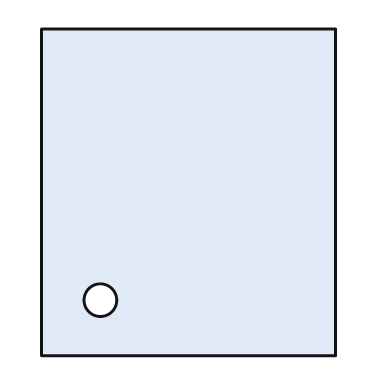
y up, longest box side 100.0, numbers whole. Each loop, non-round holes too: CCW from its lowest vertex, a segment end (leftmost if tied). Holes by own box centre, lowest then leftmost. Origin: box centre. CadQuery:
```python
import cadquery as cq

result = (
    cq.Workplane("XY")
    .moveTo(-45.0, -50.0)
    .lineTo(45.0, -50.0)
    .lineTo(45.0, 50.0)
    .lineTo(-45.0, 50.0)
    .close()
    .moveTo(-27.0, -33.0)
    .circle(5.0)
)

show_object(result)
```